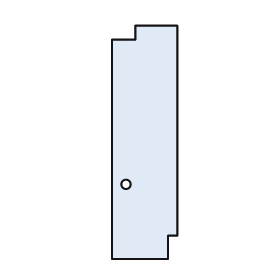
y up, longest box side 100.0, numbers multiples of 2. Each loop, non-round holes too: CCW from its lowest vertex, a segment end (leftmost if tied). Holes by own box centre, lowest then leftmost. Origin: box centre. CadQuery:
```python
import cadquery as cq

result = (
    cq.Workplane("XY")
    .moveTo(-14.0, -50.0)
    .lineTo(10.0, -50.0)
    .lineTo(10.0, -40.0)
    .lineTo(14.0, -40.0)
    .lineTo(14.0, 50.0)
    .lineTo(-4.0, 50.0)
    .lineTo(-4.0, 44.0)
    .lineTo(-14.0, 44.0)
    .close()
    .moveTo(-8.0, -18.0)
    .circle(2.0)
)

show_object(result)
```